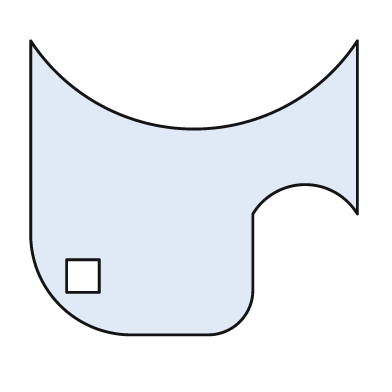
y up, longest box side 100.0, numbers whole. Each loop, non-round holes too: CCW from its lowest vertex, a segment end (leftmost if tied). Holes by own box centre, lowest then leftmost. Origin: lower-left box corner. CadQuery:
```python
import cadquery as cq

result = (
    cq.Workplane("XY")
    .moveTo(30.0, 0.0)
    .lineTo(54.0, 0.0)
    .threePointArc((64.0, 4.0), (68.0, 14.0))
    .lineTo(68.0, 37.0)
    .threePointArc((84.0, 46.0), (100.0, 37.0))
    .lineTo(100.0, 90.0)
    .threePointArc((50.0, 63.0), (0.0, 90.0))
    .lineTo(0.0, 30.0)
    .threePointArc((9.0, 9.0), (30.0, 0.0))
    .close()
    .moveTo(11.0, 13.0)
    .lineTo(21.0, 13.0)
    .lineTo(21.0, 23.0)
    .lineTo(11.0, 23.0)
    .close()
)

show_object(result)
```